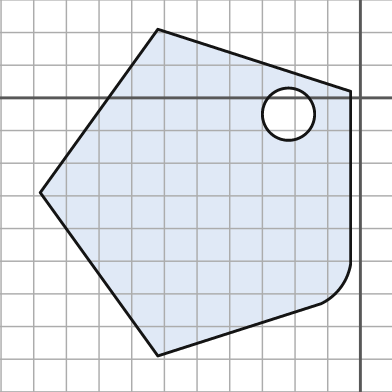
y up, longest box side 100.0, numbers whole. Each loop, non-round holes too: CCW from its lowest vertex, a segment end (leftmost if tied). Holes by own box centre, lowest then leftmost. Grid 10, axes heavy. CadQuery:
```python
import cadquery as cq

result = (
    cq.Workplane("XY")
    .moveTo(-62.0, -79.0)
    .lineTo(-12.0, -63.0)
    .threePointArc((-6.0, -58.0), (-3.0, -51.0))
    .lineTo(-3.0, 2.0)
    .lineTo(-62.0, 21.0)
    .lineTo(-98.0, -29.0)
    .close()
    .moveTo(-22.0, -5.0)
    .circle(8.0)
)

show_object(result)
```